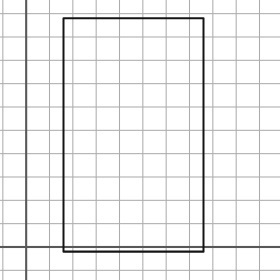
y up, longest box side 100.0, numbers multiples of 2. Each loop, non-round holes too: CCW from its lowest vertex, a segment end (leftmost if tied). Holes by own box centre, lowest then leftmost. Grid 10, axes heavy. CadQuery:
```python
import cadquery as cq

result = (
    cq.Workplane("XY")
    .moveTo(16.0, -2.0)
    .lineTo(76.0, -2.0)
    .lineTo(76.0, 98.0)
    .lineTo(16.0, 98.0)
    .close()
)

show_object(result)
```